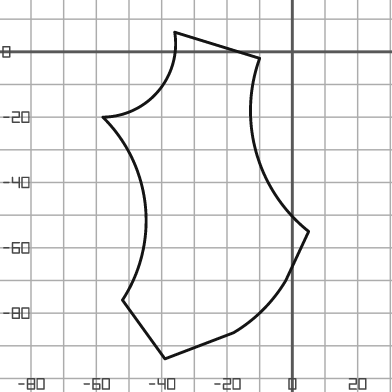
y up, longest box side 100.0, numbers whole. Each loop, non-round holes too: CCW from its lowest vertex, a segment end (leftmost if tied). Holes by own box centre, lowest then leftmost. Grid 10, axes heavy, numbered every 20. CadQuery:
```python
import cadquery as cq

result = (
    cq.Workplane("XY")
    .moveTo(-39.0, -94.0)
    .lineTo(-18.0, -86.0)
    .threePointArc((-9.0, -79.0), (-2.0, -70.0))
    .lineTo(5.0, -55.0)
    .threePointArc((-11.0, -31.0), (-10.0, -2.0))
    .lineTo(-36.0, 6.0)
    .threePointArc((-41.0, -12.0), (-58.0, -20.0))
    .threePointArc((-45.0, -47.0), (-52.0, -76.0))
    .close()
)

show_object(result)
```